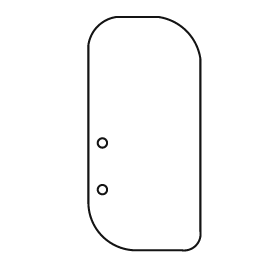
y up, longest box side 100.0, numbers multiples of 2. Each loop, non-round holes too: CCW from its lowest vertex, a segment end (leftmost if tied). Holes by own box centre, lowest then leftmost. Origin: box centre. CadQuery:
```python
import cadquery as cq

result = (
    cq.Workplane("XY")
    .moveTo(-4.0, -50.0)
    .lineTo(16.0, -50.0)
    .threePointArc((22.0, -48.0), (24.0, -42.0))
    .lineTo(24.0, 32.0)
    .threePointArc((18.0, 44.0), (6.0, 50.0))
    .lineTo(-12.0, 50.0)
    .threePointArc((-20.0, 46.0), (-24.0, 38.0))
    .lineTo(-24.0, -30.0)
    .threePointArc((-18.0, -44.0), (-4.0, -50.0))
    .close()
    .moveTo(-18.0, -24.0)
    .circle(2.0)
    .moveTo(-18.0, -4.0)
    .circle(2.0)
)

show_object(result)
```